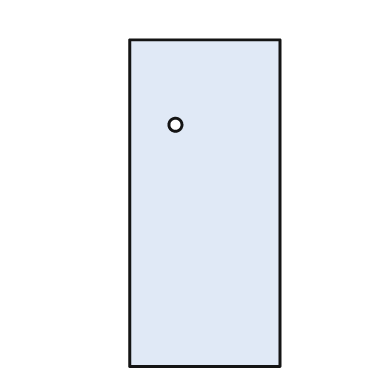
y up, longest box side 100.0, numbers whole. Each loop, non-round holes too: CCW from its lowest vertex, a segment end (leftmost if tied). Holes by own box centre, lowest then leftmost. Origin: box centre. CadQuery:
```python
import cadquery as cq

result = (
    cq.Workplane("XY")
    .moveTo(-23.0, -50.0)
    .lineTo(23.0, -50.0)
    .lineTo(23.0, 50.0)
    .lineTo(-23.0, 50.0)
    .close()
    .moveTo(-9.0, 24.0)
    .circle(2.0)
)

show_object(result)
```